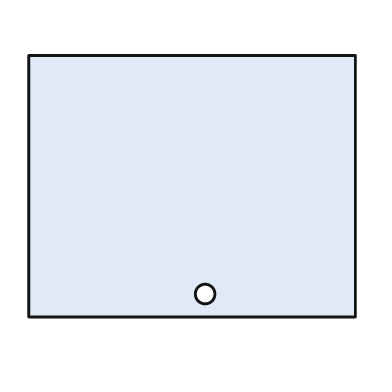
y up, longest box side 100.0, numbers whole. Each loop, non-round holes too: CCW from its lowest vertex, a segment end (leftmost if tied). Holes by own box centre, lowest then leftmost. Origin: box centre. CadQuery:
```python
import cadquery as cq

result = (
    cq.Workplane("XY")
    .moveTo(-50.0, -40.0)
    .lineTo(50.0, -40.0)
    .lineTo(50.0, 40.0)
    .lineTo(-50.0, 40.0)
    .close()
    .moveTo(4.0, -33.0)
    .circle(3.0)
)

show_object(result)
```